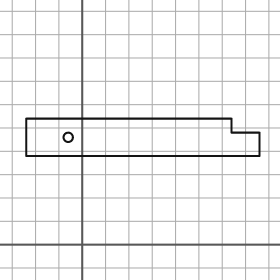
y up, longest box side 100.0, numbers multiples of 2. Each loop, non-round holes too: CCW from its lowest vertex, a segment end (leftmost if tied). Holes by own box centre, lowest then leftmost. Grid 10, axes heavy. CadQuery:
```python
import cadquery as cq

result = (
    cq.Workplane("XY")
    .moveTo(-24.0, 38.0)
    .lineTo(76.0, 38.0)
    .lineTo(76.0, 48.0)
    .lineTo(64.0, 48.0)
    .lineTo(64.0, 54.0)
    .lineTo(-24.0, 54.0)
    .close()
    .moveTo(-6.0, 46.0)
    .circle(2.0)
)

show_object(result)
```